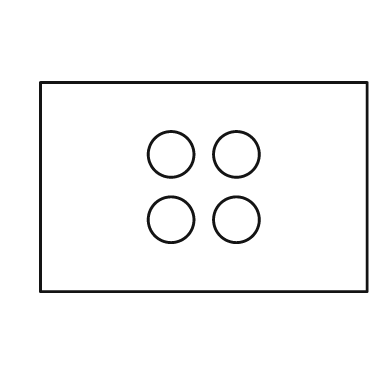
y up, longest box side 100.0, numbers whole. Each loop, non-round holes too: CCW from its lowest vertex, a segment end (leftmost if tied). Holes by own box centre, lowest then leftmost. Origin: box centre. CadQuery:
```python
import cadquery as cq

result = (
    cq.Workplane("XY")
    .moveTo(-50.0, -32.0)
    .lineTo(50.0, -32.0)
    .lineTo(50.0, 32.0)
    .lineTo(-50.0, 32.0)
    .close()
    .moveTo(-10.0, -10.0)
    .circle(7.0)
    .moveTo(10.0, -10.0)
    .circle(7.0)
    .moveTo(-10.0, 10.0)
    .circle(7.0)
    .moveTo(10.0, 10.0)
    .circle(7.0)
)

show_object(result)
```